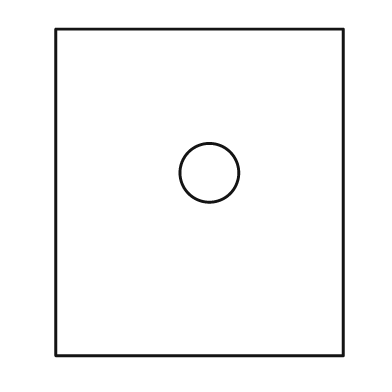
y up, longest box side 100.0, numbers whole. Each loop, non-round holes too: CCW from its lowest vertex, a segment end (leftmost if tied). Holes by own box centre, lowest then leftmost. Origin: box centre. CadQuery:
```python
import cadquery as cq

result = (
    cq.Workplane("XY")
    .moveTo(-44.0, -50.0)
    .lineTo(44.0, -50.0)
    .lineTo(44.0, 50.0)
    .lineTo(-44.0, 50.0)
    .close()
    .moveTo(3.0, 6.0)
    .circle(9.0)
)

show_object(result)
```